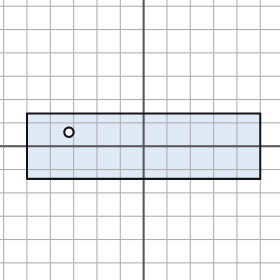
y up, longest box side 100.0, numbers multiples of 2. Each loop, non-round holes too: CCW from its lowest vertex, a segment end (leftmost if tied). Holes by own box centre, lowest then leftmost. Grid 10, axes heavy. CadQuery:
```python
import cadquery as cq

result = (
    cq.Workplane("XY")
    .moveTo(-50.0, -14.0)
    .lineTo(50.0, -14.0)
    .lineTo(50.0, 14.0)
    .lineTo(-50.0, 14.0)
    .close()
    .moveTo(-32.0, 6.0)
    .circle(2.0)
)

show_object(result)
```